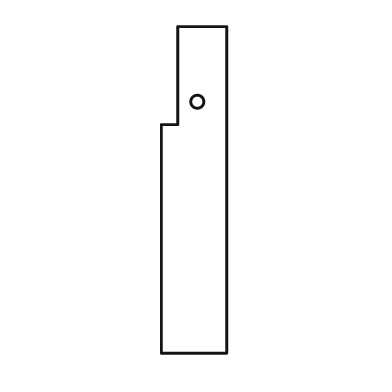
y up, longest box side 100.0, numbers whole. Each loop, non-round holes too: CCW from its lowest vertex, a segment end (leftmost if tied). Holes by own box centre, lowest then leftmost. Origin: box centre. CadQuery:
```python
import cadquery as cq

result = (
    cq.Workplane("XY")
    .moveTo(-10.0, -50.0)
    .lineTo(10.0, -50.0)
    .lineTo(10.0, 50.0)
    .lineTo(-5.0, 50.0)
    .lineTo(-5.0, 20.0)
    .lineTo(-10.0, 20.0)
    .close()
    .moveTo(1.0, 27.0)
    .circle(2.0)
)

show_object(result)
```